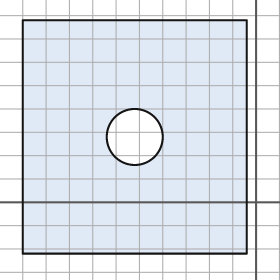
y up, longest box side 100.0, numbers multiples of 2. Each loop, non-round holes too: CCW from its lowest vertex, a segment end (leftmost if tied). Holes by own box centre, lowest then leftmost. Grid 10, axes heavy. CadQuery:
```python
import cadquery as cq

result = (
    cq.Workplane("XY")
    .moveTo(-100.0, -22.0)
    .lineTo(-4.0, -22.0)
    .lineTo(-4.0, 78.0)
    .lineTo(-100.0, 78.0)
    .close()
    .moveTo(-52.0, 28.0)
    .circle(12.0)
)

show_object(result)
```